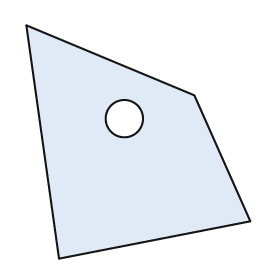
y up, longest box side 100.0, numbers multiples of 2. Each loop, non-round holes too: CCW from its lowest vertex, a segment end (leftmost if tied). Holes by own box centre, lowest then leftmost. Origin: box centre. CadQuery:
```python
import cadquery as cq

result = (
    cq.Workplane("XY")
    .moveTo(-34.0, -50.0)
    .lineTo(48.0, -34.0)
    .lineTo(24.0, 20.0)
    .lineTo(-48.0, 50.0)
    .close()
    .moveTo(-6.0, 10.0)
    .circle(8.0)
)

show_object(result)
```